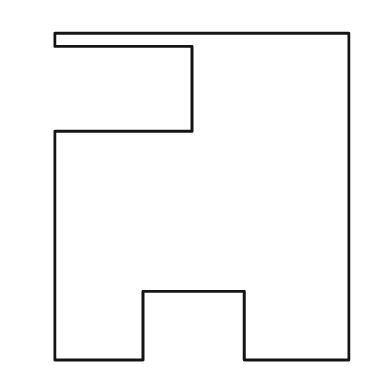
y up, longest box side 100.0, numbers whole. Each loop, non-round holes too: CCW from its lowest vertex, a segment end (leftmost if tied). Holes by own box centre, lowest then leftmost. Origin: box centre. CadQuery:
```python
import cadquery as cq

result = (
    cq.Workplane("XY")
    .moveTo(-45.0, -50.0)
    .lineTo(-18.0, -50.0)
    .lineTo(-18.0, -29.0)
    .lineTo(13.0, -29.0)
    .lineTo(13.0, -50.0)
    .lineTo(45.0, -50.0)
    .lineTo(45.0, 50.0)
    .lineTo(-45.0, 50.0)
    .lineTo(-45.0, 46.0)
    .lineTo(-3.0, 46.0)
    .lineTo(-3.0, 20.0)
    .lineTo(-45.0, 20.0)
    .close()
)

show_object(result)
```